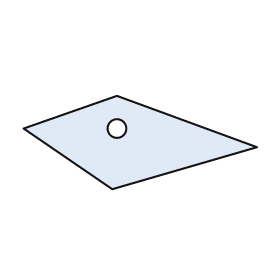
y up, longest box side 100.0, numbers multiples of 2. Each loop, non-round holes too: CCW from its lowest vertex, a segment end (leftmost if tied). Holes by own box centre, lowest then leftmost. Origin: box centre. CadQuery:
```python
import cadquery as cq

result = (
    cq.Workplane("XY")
    .moveTo(-12.0, -20.0)
    .lineTo(50.0, -2.0)
    .lineTo(-10.0, 20.0)
    .lineTo(-50.0, 6.0)
    .close()
    .moveTo(-10.0, 6.0)
    .circle(4.0)
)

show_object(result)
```